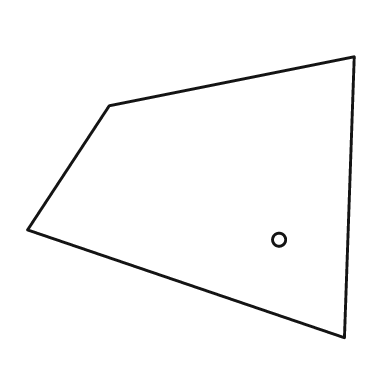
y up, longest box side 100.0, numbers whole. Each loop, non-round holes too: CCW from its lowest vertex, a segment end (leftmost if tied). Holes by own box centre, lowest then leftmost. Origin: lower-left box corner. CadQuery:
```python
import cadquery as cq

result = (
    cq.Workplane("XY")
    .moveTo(97.0, 0.0)
    .lineTo(100.0, 86.0)
    .lineTo(25.0, 71.0)
    .lineTo(0.0, 33.0)
    .close()
    .moveTo(77.0, 30.0)
    .circle(2.0)
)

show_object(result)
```